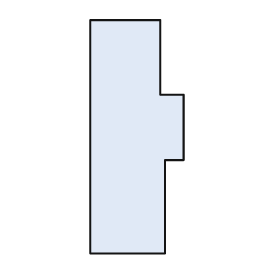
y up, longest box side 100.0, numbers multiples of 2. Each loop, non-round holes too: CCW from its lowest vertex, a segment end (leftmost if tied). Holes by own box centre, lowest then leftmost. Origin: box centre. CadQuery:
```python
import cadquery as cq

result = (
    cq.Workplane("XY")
    .moveTo(-20.0, -50.0)
    .lineTo(12.0, -50.0)
    .lineTo(12.0, -10.0)
    .lineTo(20.0, -10.0)
    .lineTo(20.0, 18.0)
    .lineTo(10.0, 18.0)
    .lineTo(10.0, 50.0)
    .lineTo(-20.0, 50.0)
    .close()
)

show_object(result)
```